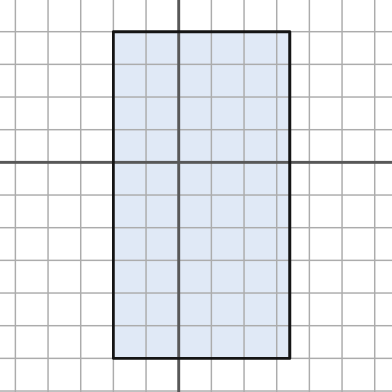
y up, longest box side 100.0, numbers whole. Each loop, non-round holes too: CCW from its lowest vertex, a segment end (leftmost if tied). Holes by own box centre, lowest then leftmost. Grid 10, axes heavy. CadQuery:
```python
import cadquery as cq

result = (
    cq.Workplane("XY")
    .moveTo(-20.0, -60.0)
    .lineTo(34.0, -60.0)
    .lineTo(34.0, 40.0)
    .lineTo(-20.0, 40.0)
    .close()
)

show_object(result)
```